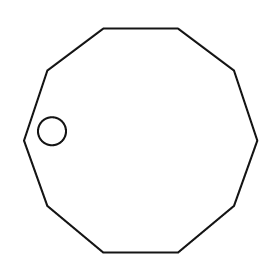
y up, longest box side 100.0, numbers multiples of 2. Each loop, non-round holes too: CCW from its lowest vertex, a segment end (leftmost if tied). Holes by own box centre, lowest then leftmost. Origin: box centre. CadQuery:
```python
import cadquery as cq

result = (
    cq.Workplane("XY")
    .moveTo(-16.0, -48.0)
    .lineTo(16.0, -48.0)
    .lineTo(40.0, -28.0)
    .lineTo(50.0, 0.0)
    .lineTo(40.0, 30.0)
    .lineTo(16.0, 48.0)
    .lineTo(-16.0, 48.0)
    .lineTo(-40.0, 30.0)
    .lineTo(-50.0, 0.0)
    .lineTo(-40.0, -28.0)
    .close()
    .moveTo(-38.0, 4.0)
    .circle(6.0)
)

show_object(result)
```